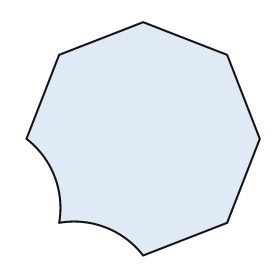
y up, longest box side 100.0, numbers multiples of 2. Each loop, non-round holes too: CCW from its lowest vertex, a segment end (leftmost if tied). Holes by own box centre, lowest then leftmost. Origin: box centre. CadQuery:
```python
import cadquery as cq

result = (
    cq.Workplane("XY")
    .moveTo(0.0, -50.0)
    .lineTo(36.0, -36.0)
    .lineTo(50.0, 0.0)
    .lineTo(36.0, 36.0)
    .lineTo(0.0, 50.0)
    .lineTo(-36.0, 36.0)
    .lineTo(-50.0, 0.0)
    .threePointArc((-38.0, -16.0), (-36.0, -36.0))
    .threePointArc((-16.0, -38.0), (0.0, -50.0))
    .close()
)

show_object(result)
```